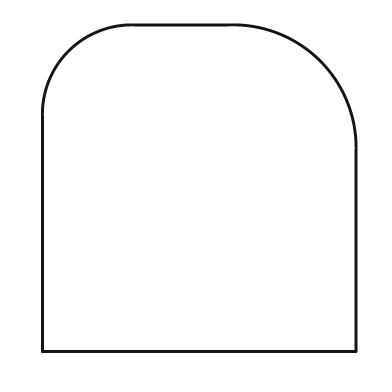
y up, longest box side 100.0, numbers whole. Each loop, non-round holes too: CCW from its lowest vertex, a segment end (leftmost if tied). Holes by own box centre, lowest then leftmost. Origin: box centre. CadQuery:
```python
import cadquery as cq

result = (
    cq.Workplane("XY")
    .moveTo(-48.0, -50.0)
    .lineTo(48.0, -50.0)
    .lineTo(48.0, 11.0)
    .threePointArc((37.0, 39.0), (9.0, 50.0))
    .lineTo(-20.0, 50.0)
    .threePointArc((-40.0, 42.0), (-48.0, 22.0))
    .close()
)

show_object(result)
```